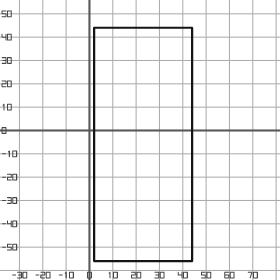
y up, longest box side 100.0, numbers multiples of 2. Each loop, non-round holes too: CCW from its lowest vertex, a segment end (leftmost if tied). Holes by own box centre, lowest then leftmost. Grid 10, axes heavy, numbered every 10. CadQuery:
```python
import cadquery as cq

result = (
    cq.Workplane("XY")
    .moveTo(2.0, -56.0)
    .lineTo(44.0, -56.0)
    .lineTo(44.0, 44.0)
    .lineTo(2.0, 44.0)
    .close()
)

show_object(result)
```